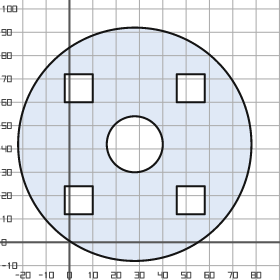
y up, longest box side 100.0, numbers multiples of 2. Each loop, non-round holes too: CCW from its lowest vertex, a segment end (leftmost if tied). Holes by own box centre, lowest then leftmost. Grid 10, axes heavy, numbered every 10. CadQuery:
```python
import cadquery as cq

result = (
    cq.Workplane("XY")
    .moveTo(28.0, 42.0)
    .circle(50.0)
    .moveTo(-2.0, 12.0)
    .lineTo(10.0, 12.0)
    .lineTo(10.0, 24.0)
    .lineTo(-2.0, 24.0)
    .close()
    .moveTo(46.0, 12.0)
    .lineTo(58.0, 12.0)
    .lineTo(58.0, 24.0)
    .lineTo(46.0, 24.0)
    .close()
    .moveTo(28.0, 42.0)
    .circle(12.0)
    .moveTo(-2.0, 60.0)
    .lineTo(10.0, 60.0)
    .lineTo(10.0, 72.0)
    .lineTo(-2.0, 72.0)
    .close()
    .moveTo(46.0, 60.0)
    .lineTo(58.0, 60.0)
    .lineTo(58.0, 72.0)
    .lineTo(46.0, 72.0)
    .close()
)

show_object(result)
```